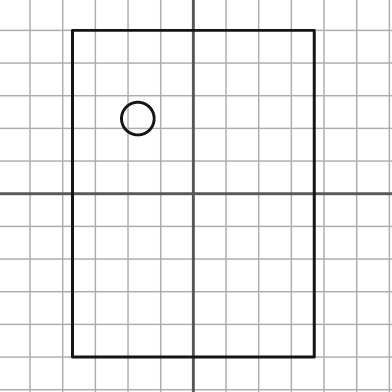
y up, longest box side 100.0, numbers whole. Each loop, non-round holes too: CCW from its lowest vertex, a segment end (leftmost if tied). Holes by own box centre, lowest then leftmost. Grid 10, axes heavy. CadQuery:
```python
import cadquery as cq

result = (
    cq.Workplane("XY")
    .moveTo(-37.0, -50.0)
    .lineTo(37.0, -50.0)
    .lineTo(37.0, 50.0)
    .lineTo(-37.0, 50.0)
    .close()
    .moveTo(-17.0, 23.0)
    .circle(5.0)
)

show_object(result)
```